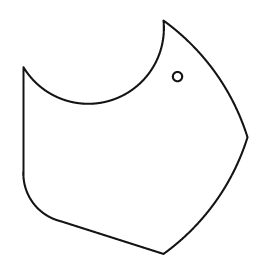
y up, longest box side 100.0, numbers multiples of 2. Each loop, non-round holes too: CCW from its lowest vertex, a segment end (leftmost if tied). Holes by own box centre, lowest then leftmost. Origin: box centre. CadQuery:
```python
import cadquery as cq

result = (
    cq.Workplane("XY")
    .moveTo(12.0, -50.0)
    .threePointArc((34.0, -28.0), (48.0, 0.0))
    .threePointArc((34.0, 28.0), (12.0, 50.0))
    .threePointArc((-10.0, 16.0), (-48.0, 30.0))
    .lineTo(-48.0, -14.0)
    .threePointArc((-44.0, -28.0), (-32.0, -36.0))
    .close()
    .moveTo(18.0, 26.0)
    .circle(2.0)
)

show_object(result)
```